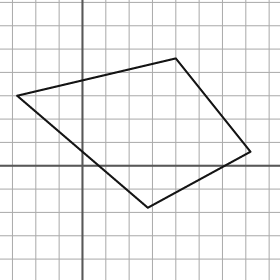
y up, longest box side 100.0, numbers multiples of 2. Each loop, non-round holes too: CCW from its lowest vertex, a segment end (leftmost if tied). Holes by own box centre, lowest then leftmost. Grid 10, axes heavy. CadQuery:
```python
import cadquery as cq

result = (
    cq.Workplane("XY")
    .moveTo(28.0, -18.0)
    .lineTo(72.0, 6.0)
    .lineTo(40.0, 46.0)
    .lineTo(-28.0, 30.0)
    .close()
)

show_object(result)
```